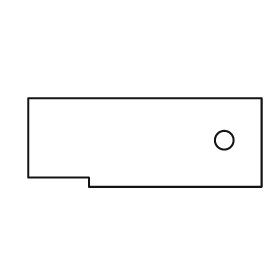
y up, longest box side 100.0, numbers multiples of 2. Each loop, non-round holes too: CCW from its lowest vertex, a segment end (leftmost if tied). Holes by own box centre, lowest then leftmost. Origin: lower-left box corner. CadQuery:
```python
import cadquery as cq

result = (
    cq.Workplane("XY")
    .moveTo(26.0, 0.0)
    .lineTo(100.0, 0.0)
    .lineTo(100.0, 38.0)
    .lineTo(0.0, 38.0)
    .lineTo(0.0, 4.0)
    .lineTo(26.0, 4.0)
    .close()
    .moveTo(84.0, 20.0)
    .circle(4.0)
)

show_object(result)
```